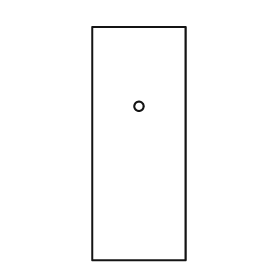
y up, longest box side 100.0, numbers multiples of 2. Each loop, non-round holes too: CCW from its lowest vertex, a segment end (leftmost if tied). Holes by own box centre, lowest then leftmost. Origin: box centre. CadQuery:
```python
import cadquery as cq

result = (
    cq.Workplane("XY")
    .moveTo(-20.0, -50.0)
    .lineTo(20.0, -50.0)
    .lineTo(20.0, 50.0)
    .lineTo(-20.0, 50.0)
    .close()
    .moveTo(0.0, 16.0)
    .circle(2.0)
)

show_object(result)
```